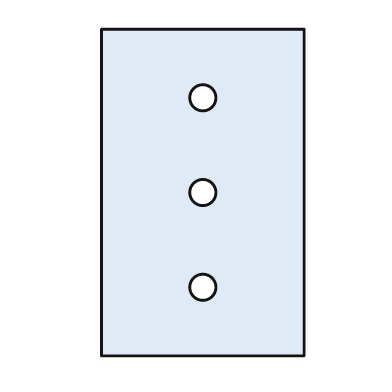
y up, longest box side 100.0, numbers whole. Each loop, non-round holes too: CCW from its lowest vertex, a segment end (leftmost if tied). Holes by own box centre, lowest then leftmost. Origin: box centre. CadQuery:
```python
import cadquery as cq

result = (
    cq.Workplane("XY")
    .moveTo(-31.0, -50.0)
    .lineTo(31.0, -50.0)
    .lineTo(31.0, 50.0)
    .lineTo(-31.0, 50.0)
    .close()
    .moveTo(0.0, -29.0)
    .circle(4.0)
    .moveTo(0.0, 0.0)
    .circle(4.0)
    .moveTo(0.0, 29.0)
    .circle(4.0)
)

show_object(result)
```